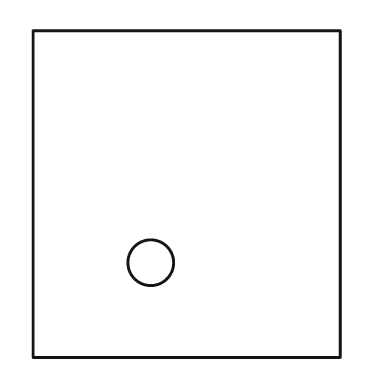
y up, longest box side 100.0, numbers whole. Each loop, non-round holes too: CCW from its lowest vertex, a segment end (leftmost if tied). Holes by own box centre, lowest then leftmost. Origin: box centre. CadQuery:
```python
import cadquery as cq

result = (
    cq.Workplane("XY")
    .moveTo(-47.0, -50.0)
    .lineTo(47.0, -50.0)
    .lineTo(47.0, 50.0)
    .lineTo(-47.0, 50.0)
    .close()
    .moveTo(-11.0, -21.0)
    .circle(7.0)
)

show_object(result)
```